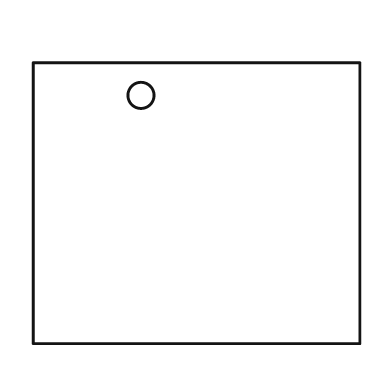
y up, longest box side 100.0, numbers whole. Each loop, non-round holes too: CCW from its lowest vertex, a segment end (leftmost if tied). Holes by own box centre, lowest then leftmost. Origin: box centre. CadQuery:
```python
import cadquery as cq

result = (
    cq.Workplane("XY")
    .moveTo(-50.0, -43.0)
    .lineTo(50.0, -43.0)
    .lineTo(50.0, 43.0)
    .lineTo(-50.0, 43.0)
    .close()
    .moveTo(-17.0, 33.0)
    .circle(4.0)
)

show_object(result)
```